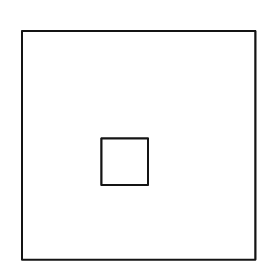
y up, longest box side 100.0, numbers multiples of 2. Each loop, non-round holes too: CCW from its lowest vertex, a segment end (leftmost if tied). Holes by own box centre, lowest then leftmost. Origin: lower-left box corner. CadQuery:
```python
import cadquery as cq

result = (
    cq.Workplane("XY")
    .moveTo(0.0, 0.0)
    .lineTo(100.0, 0.0)
    .lineTo(100.0, 98.0)
    .lineTo(0.0, 98.0)
    .close()
    .moveTo(34.0, 32.0)
    .lineTo(54.0, 32.0)
    .lineTo(54.0, 52.0)
    .lineTo(34.0, 52.0)
    .close()
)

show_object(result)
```